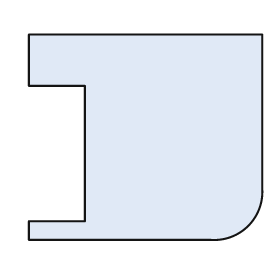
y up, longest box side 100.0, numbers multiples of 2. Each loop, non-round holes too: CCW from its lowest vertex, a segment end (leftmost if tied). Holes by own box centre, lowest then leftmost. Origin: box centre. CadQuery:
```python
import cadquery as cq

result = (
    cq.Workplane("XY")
    .moveTo(-50.0, -44.0)
    .lineTo(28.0, -44.0)
    .threePointArc((44.0, -38.0), (50.0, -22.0))
    .lineTo(50.0, 44.0)
    .lineTo(-50.0, 44.0)
    .lineTo(-50.0, 22.0)
    .lineTo(-26.0, 22.0)
    .lineTo(-26.0, -36.0)
    .lineTo(-50.0, -36.0)
    .close()
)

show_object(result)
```